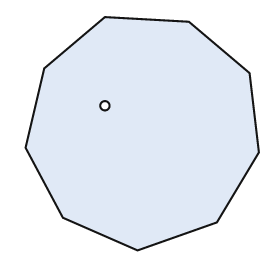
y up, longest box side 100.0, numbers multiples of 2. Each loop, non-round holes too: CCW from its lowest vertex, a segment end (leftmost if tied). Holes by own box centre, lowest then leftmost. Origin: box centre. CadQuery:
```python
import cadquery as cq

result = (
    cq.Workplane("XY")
    .moveTo(-2.0, -50.0)
    .lineTo(32.0, -38.0)
    .lineTo(50.0, -8.0)
    .lineTo(46.0, 26.0)
    .lineTo(20.0, 48.0)
    .lineTo(-16.0, 50.0)
    .lineTo(-42.0, 28.0)
    .lineTo(-50.0, -6.0)
    .lineTo(-34.0, -36.0)
    .close()
    .moveTo(-16.0, 12.0)
    .circle(2.0)
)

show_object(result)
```